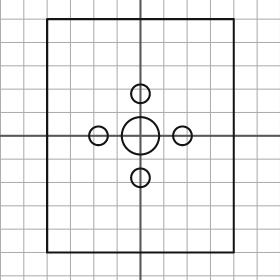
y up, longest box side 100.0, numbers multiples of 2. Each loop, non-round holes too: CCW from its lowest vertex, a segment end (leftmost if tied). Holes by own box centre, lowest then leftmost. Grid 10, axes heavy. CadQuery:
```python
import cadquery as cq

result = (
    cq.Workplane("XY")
    .moveTo(-40.0, -50.0)
    .lineTo(40.0, -50.0)
    .lineTo(40.0, 50.0)
    .lineTo(-40.0, 50.0)
    .close()
    .moveTo(0.0, -18.0)
    .circle(4.0)
    .moveTo(-18.0, 0.0)
    .circle(4.0)
    .moveTo(0.0, 0.0)
    .circle(8.0)
    .moveTo(18.0, 0.0)
    .circle(4.0)
    .moveTo(0.0, 18.0)
    .circle(4.0)
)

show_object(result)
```